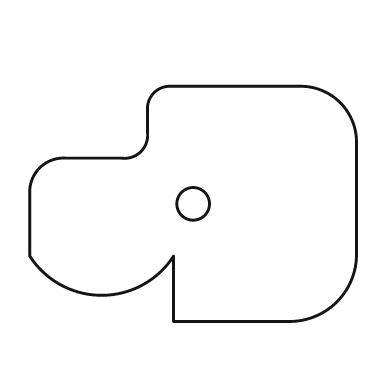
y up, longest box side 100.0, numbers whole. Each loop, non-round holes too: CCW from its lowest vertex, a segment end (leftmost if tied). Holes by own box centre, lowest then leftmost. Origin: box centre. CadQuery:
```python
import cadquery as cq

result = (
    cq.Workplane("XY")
    .moveTo(-6.0, -36.0)
    .lineTo(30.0, -36.0)
    .threePointArc((44.0, -30.0), (50.0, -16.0))
    .lineTo(50.0, 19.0)
    .threePointArc((45.0, 31.0), (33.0, 36.0))
    .lineTo(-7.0, 36.0)
    .threePointArc((-12.0, 34.0), (-14.0, 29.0))
    .lineTo(-14.0, 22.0)
    .threePointArc((-16.0, 16.0), (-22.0, 14.0))
    .lineTo(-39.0, 14.0)
    .threePointArc((-47.0, 11.0), (-50.0, 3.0))
    .lineTo(-50.0, -16.0)
    .threePointArc((-28.0, -28.0), (-6.0, -16.0))
    .close()
    .moveTo(0.0, 0.0)
    .circle(5.0)
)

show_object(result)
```